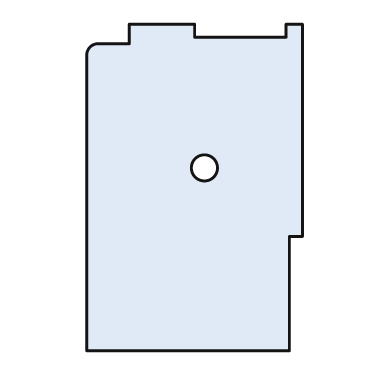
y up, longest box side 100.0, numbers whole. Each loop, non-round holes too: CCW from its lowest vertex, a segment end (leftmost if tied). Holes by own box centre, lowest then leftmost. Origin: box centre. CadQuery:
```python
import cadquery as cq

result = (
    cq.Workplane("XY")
    .moveTo(-33.0, -50.0)
    .lineTo(29.0, -50.0)
    .lineTo(29.0, -15.0)
    .lineTo(33.0, -15.0)
    .lineTo(33.0, 50.0)
    .lineTo(28.0, 50.0)
    .lineTo(28.0, 46.0)
    .lineTo(0.0, 46.0)
    .lineTo(0.0, 50.0)
    .lineTo(-20.0, 50.0)
    .lineTo(-20.0, 44.0)
    .lineTo(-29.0, 44.0)
    .threePointArc((-32.0, 43.0), (-33.0, 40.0))
    .close()
    .moveTo(3.0, 6.0)
    .circle(4.0)
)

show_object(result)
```